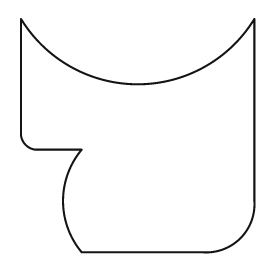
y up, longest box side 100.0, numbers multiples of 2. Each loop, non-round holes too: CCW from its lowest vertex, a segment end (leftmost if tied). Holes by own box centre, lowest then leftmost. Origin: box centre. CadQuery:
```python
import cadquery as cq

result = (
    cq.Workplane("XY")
    .moveTo(-24.0, -50.0)
    .lineTo(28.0, -50.0)
    .threePointArc((44.0, -44.0), (50.0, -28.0))
    .lineTo(50.0, 50.0)
    .threePointArc((0.0, 22.0), (-50.0, 50.0))
    .lineTo(-50.0, 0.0)
    .threePointArc((-48.0, -4.0), (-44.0, -6.0))
    .lineTo(-24.0, -6.0)
    .threePointArc((-32.0, -28.0), (-24.0, -50.0))
    .close()
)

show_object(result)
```